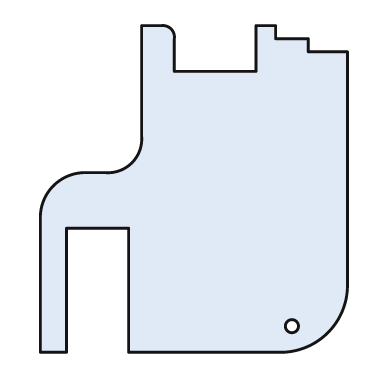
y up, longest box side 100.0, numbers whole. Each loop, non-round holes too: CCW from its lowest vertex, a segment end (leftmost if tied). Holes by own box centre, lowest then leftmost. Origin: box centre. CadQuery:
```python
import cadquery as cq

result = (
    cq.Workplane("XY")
    .moveTo(-47.0, -50.0)
    .lineTo(-39.0, -50.0)
    .lineTo(-39.0, -12.0)
    .lineTo(-20.0, -12.0)
    .lineTo(-20.0, -50.0)
    .lineTo(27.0, -50.0)
    .threePointArc((41.0, -44.0), (47.0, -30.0))
    .lineTo(47.0, 42.0)
    .lineTo(35.0, 42.0)
    .lineTo(35.0, 46.0)
    .lineTo(25.0, 46.0)
    .lineTo(25.0, 50.0)
    .lineTo(19.0, 50.0)
    .lineTo(19.0, 36.0)
    .lineTo(-6.0, 36.0)
    .lineTo(-6.0, 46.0)
    .threePointArc((-7.0, 49.0), (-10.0, 50.0))
    .lineTo(-16.0, 50.0)
    .lineTo(-16.0, 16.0)
    .threePointArc((-19.0, 8.0), (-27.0, 5.0))
    .lineTo(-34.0, 5.0)
    .threePointArc((-43.0, 1.0), (-47.0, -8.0))
    .close()
    .moveTo(30.0, -42.0)
    .circle(2.0)
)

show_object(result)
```